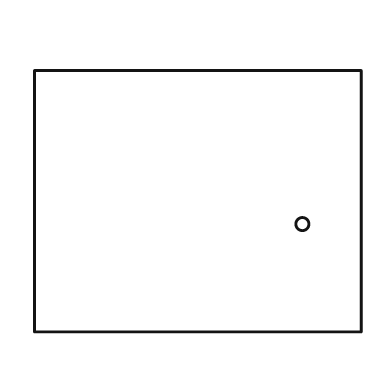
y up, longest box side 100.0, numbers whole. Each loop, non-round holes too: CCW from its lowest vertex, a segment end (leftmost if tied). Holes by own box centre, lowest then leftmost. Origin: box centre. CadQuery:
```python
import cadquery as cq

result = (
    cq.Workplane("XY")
    .moveTo(-50.0, -40.0)
    .lineTo(50.0, -40.0)
    .lineTo(50.0, 40.0)
    .lineTo(-50.0, 40.0)
    .close()
    .moveTo(32.0, -7.0)
    .circle(2.0)
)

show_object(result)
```